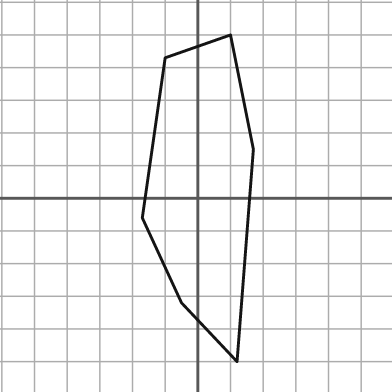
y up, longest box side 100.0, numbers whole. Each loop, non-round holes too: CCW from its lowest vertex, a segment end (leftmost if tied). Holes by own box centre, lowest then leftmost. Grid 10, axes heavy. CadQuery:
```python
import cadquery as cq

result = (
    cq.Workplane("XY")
    .moveTo(12.0, -50.0)
    .lineTo(17.0, 15.0)
    .lineTo(10.0, 50.0)
    .lineTo(-10.0, 43.0)
    .lineTo(-17.0, -6.0)
    .lineTo(-5.0, -32.0)
    .close()
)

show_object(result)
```